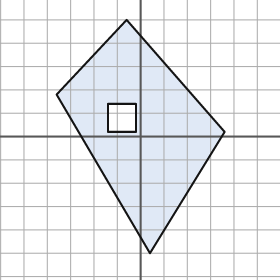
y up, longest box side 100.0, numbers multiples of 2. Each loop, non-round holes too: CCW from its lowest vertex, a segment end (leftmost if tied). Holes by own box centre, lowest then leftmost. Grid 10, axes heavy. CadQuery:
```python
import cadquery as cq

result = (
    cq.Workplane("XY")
    .moveTo(4.0, -50.0)
    .lineTo(36.0, 2.0)
    .lineTo(-6.0, 50.0)
    .lineTo(-36.0, 18.0)
    .close()
    .moveTo(-14.0, 2.0)
    .lineTo(-2.0, 2.0)
    .lineTo(-2.0, 14.0)
    .lineTo(-14.0, 14.0)
    .close()
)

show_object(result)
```